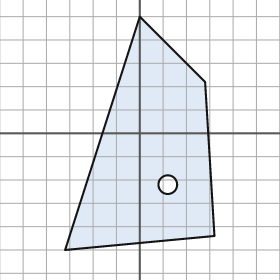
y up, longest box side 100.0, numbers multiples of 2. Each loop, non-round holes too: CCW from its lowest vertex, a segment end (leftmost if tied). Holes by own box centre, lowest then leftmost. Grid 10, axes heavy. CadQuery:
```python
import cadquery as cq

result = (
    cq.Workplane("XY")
    .moveTo(-32.0, -50.0)
    .lineTo(32.0, -44.0)
    .lineTo(28.0, 22.0)
    .lineTo(0.0, 50.0)
    .close()
    .moveTo(12.0, -22.0)
    .circle(4.0)
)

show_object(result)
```